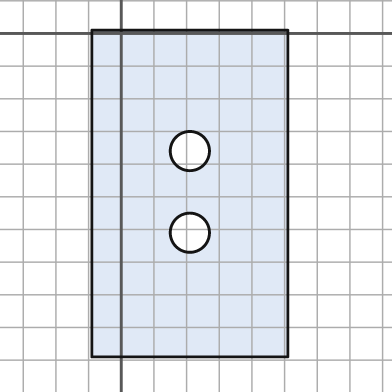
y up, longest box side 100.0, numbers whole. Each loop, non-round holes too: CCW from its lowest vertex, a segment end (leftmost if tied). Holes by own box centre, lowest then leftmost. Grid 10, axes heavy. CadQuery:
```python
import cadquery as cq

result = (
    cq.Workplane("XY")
    .moveTo(-9.0, -99.0)
    .lineTo(51.0, -99.0)
    .lineTo(51.0, 1.0)
    .lineTo(-9.0, 1.0)
    .close()
    .moveTo(21.0, -61.0)
    .circle(6.0)
    .moveTo(21.0, -36.0)
    .circle(6.0)
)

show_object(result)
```